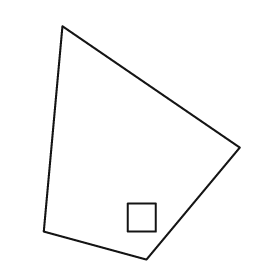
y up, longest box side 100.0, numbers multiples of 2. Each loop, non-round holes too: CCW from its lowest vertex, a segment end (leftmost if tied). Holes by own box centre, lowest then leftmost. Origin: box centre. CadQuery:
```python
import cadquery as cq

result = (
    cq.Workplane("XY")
    .moveTo(2.0, -50.0)
    .lineTo(42.0, -2.0)
    .lineTo(-34.0, 50.0)
    .lineTo(-42.0, -38.0)
    .close()
    .moveTo(-6.0, -38.0)
    .lineTo(6.0, -38.0)
    .lineTo(6.0, -26.0)
    .lineTo(-6.0, -26.0)
    .close()
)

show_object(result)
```